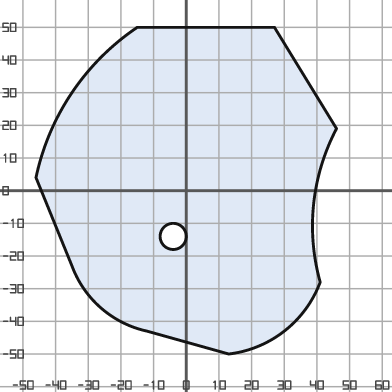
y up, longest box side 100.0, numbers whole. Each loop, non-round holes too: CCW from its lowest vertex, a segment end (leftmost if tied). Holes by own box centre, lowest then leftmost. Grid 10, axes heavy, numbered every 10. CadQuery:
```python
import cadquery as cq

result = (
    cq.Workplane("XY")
    .moveTo(13.0, -50.0)
    .threePointArc((30.0, -43.0), (41.0, -28.0))
    .threePointArc((39.0, -4.0), (46.0, 19.0))
    .lineTo(27.0, 50.0)
    .lineTo(-15.0, 50.0)
    .threePointArc((-35.0, 30.0), (-46.0, 4.0))
    .lineTo(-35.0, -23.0)
    .threePointArc((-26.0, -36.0), (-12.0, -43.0))
    .close()
    .moveTo(-4.0, -14.0)
    .circle(4.0)
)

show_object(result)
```